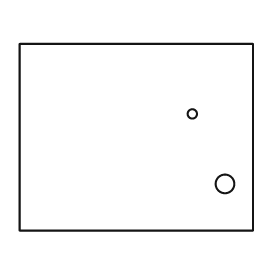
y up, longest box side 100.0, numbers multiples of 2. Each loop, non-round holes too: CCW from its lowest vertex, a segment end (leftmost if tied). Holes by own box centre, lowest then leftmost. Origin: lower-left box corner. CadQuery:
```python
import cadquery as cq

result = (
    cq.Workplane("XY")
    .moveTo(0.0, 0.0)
    .lineTo(100.0, 0.0)
    .lineTo(100.0, 80.0)
    .lineTo(0.0, 80.0)
    .close()
    .moveTo(88.0, 20.0)
    .circle(4.0)
    .moveTo(74.0, 50.0)
    .circle(2.0)
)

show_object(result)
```